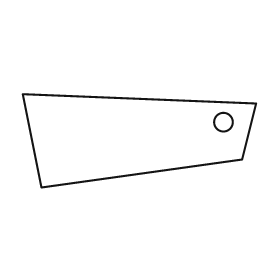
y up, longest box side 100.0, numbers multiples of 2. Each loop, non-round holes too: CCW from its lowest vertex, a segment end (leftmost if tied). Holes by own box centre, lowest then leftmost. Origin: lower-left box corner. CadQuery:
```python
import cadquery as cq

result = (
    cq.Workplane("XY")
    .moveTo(8.0, 0.0)
    .lineTo(94.0, 12.0)
    .lineTo(100.0, 36.0)
    .lineTo(0.0, 40.0)
    .close()
    .moveTo(86.0, 28.0)
    .circle(4.0)
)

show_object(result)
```